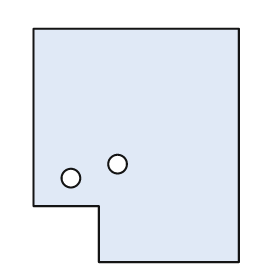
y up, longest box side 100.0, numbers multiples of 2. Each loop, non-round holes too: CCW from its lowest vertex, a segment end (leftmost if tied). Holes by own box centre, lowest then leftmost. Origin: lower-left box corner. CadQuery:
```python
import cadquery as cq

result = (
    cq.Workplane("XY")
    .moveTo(28.0, 0.0)
    .lineTo(88.0, 0.0)
    .lineTo(88.0, 100.0)
    .lineTo(0.0, 100.0)
    .lineTo(0.0, 24.0)
    .lineTo(28.0, 24.0)
    .close()
    .moveTo(16.0, 36.0)
    .circle(4.0)
    .moveTo(36.0, 42.0)
    .circle(4.0)
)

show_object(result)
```